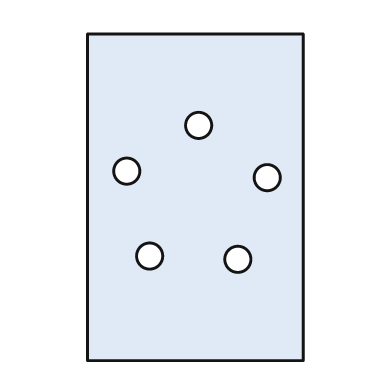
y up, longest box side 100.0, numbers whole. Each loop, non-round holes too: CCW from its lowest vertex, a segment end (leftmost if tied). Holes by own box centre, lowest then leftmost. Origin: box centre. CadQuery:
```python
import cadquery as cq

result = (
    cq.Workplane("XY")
    .moveTo(-33.0, -50.0)
    .lineTo(33.0, -50.0)
    .lineTo(33.0, 50.0)
    .lineTo(-33.0, 50.0)
    .close()
    .moveTo(13.0, -19.0)
    .circle(4.0)
    .moveTo(-14.0, -18.0)
    .circle(4.0)
    .moveTo(22.0, 6.0)
    .circle(4.0)
    .moveTo(-21.0, 8.0)
    .circle(4.0)
    .moveTo(1.0, 22.0)
    .circle(4.0)
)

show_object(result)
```